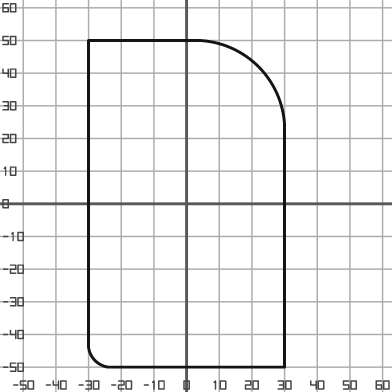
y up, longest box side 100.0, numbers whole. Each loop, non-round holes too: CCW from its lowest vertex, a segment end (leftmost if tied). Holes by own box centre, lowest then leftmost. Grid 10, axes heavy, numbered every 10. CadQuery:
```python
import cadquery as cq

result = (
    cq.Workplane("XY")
    .moveTo(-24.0, -50.0)
    .lineTo(30.0, -50.0)
    .lineTo(30.0, 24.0)
    .threePointArc((22.0, 42.0), (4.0, 50.0))
    .lineTo(-30.0, 50.0)
    .lineTo(-30.0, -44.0)
    .threePointArc((-28.0, -48.0), (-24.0, -50.0))
    .close()
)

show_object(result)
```